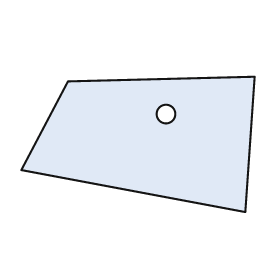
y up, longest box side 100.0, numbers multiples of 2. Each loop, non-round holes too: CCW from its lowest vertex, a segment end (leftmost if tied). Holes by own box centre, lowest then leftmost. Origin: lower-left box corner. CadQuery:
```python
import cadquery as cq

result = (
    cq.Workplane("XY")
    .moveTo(96.0, 0.0)
    .lineTo(100.0, 58.0)
    .lineTo(20.0, 56.0)
    .lineTo(0.0, 18.0)
    .close()
    .moveTo(62.0, 42.0)
    .circle(4.0)
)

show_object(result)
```